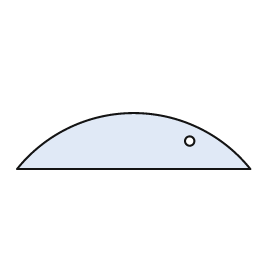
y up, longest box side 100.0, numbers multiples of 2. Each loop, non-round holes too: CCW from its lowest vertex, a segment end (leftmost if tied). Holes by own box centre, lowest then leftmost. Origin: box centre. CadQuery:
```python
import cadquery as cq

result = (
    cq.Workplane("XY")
    .moveTo(-50.0, -12.0)
    .lineTo(50.0, -12.0)
    .threePointArc((0.0, 12.0), (-50.0, -12.0))
    .close()
    .moveTo(24.0, 0.0)
    .circle(2.0)
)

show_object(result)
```